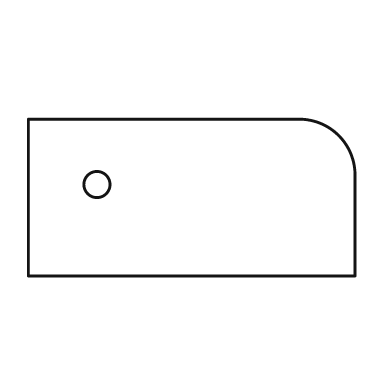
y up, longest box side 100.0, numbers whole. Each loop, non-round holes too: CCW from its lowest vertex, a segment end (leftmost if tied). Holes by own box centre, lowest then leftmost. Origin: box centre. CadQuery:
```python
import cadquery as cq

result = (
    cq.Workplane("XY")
    .moveTo(-50.0, -24.0)
    .lineTo(50.0, -24.0)
    .lineTo(50.0, 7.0)
    .threePointArc((45.0, 19.0), (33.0, 24.0))
    .lineTo(-50.0, 24.0)
    .close()
    .moveTo(-29.0, 4.0)
    .circle(4.0)
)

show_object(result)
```